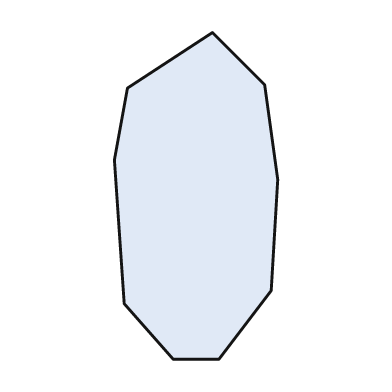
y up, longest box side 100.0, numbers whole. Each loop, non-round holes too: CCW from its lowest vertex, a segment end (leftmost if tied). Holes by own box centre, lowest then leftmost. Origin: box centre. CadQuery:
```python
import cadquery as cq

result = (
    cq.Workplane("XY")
    .moveTo(-7.0, -50.0)
    .lineTo(7.0, -50.0)
    .lineTo(23.0, -29.0)
    .lineTo(25.0, 5.0)
    .lineTo(21.0, 34.0)
    .lineTo(5.0, 50.0)
    .lineTo(-21.0, 33.0)
    .lineTo(-25.0, 11.0)
    .lineTo(-22.0, -33.0)
    .close()
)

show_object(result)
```